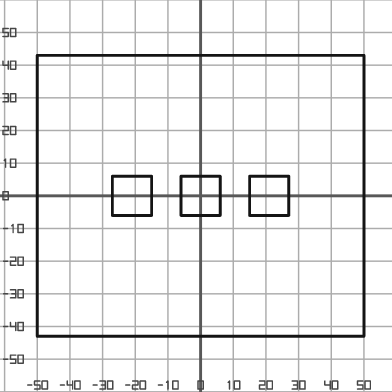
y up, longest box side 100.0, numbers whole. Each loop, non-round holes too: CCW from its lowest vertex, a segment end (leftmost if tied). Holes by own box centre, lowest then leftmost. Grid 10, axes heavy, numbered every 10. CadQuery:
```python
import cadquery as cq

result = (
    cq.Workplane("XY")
    .moveTo(-50.0, -43.0)
    .lineTo(50.0, -43.0)
    .lineTo(50.0, 43.0)
    .lineTo(-50.0, 43.0)
    .close()
    .moveTo(-27.0, -6.0)
    .lineTo(-15.0, -6.0)
    .lineTo(-15.0, 6.0)
    .lineTo(-27.0, 6.0)
    .close()
    .moveTo(-6.0, -6.0)
    .lineTo(6.0, -6.0)
    .lineTo(6.0, 6.0)
    .lineTo(-6.0, 6.0)
    .close()
    .moveTo(15.0, -6.0)
    .lineTo(27.0, -6.0)
    .lineTo(27.0, 6.0)
    .lineTo(15.0, 6.0)
    .close()
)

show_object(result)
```